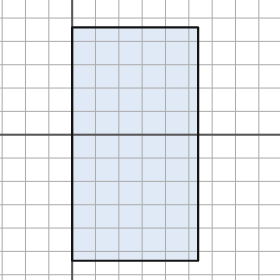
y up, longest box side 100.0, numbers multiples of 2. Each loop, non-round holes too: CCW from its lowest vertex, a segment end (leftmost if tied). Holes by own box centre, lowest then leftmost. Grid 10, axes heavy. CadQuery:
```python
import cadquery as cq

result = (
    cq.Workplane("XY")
    .moveTo(0.0, -54.0)
    .lineTo(54.0, -54.0)
    .lineTo(54.0, 46.0)
    .lineTo(0.0, 46.0)
    .close()
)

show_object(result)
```